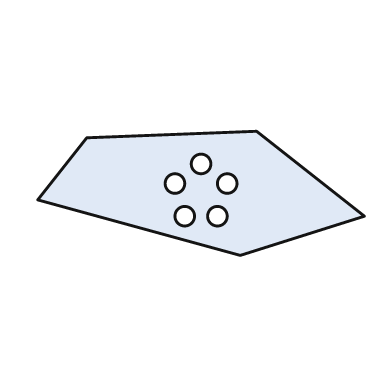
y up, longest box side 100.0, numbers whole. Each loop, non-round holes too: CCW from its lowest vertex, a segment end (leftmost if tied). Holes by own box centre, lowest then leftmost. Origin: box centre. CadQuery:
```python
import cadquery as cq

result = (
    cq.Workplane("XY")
    .moveTo(12.0, -19.0)
    .lineTo(50.0, -7.0)
    .lineTo(17.0, 19.0)
    .lineTo(-35.0, 17.0)
    .lineTo(-50.0, -2.0)
    .close()
    .moveTo(-5.0, -7.0)
    .circle(3.0)
    .moveTo(5.0, -7.0)
    .circle(3.0)
    .moveTo(-8.0, 3.0)
    .circle(3.0)
    .moveTo(8.0, 3.0)
    .circle(3.0)
    .moveTo(0.0, 9.0)
    .circle(3.0)
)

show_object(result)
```